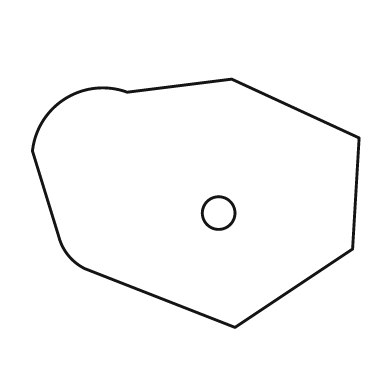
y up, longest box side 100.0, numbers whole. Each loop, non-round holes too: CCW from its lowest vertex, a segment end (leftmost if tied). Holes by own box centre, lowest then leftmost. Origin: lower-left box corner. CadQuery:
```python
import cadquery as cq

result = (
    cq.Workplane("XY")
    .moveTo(62.0, 0.0)
    .lineTo(98.0, 24.0)
    .lineTo(100.0, 58.0)
    .lineTo(61.0, 76.0)
    .lineTo(29.0, 72.0)
    .threePointArc((10.0, 70.0), (0.0, 54.0))
    .lineTo(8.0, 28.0)
    .threePointArc((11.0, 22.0), (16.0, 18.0))
    .close()
    .moveTo(57.0, 35.0)
    .circle(5.0)
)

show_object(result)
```